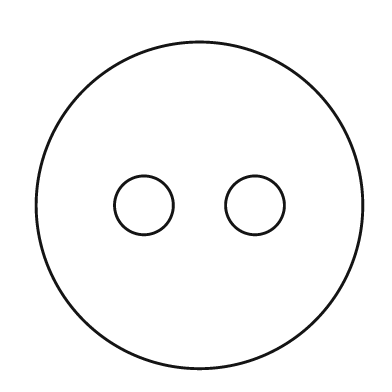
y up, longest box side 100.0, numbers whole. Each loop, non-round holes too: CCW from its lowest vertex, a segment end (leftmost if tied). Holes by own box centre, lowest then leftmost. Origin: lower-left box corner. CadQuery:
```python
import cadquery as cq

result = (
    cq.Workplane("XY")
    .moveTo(50.0, 50.0)
    .circle(50.0)
    .moveTo(33.0, 50.0)
    .circle(9.0)
    .moveTo(67.0, 50.0)
    .circle(9.0)
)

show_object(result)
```